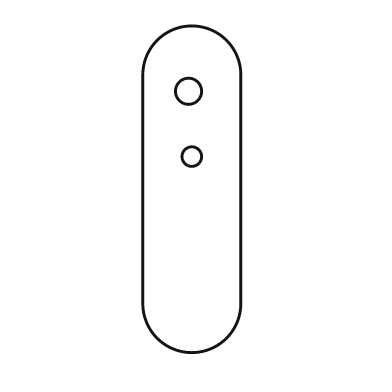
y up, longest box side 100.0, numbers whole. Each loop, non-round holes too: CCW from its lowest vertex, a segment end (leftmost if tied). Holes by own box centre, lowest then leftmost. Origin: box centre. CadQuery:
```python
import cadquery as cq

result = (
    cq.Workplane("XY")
    .moveTo(-15.0, -35.0)
    .threePointArc((0.0, -50.0), (15.0, -35.0))
    .lineTo(15.0, 35.0)
    .threePointArc((0.0, 50.0), (-15.0, 35.0))
    .close()
    .moveTo(0.0, 10.0)
    .circle(3.0)
    .moveTo(-1.0, 30.0)
    .circle(4.0)
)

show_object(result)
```